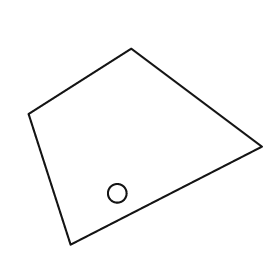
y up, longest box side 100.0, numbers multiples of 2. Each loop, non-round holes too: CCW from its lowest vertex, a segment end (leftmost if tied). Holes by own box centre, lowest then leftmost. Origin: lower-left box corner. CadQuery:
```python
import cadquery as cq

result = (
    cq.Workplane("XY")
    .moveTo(18.0, 0.0)
    .lineTo(100.0, 42.0)
    .lineTo(44.0, 84.0)
    .lineTo(0.0, 56.0)
    .close()
    .moveTo(38.0, 22.0)
    .circle(4.0)
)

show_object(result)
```